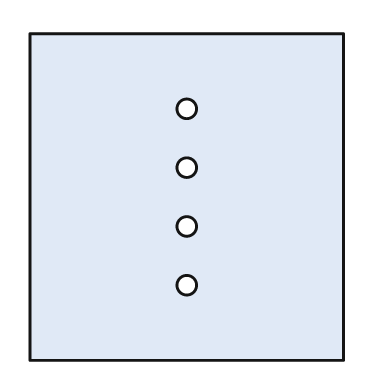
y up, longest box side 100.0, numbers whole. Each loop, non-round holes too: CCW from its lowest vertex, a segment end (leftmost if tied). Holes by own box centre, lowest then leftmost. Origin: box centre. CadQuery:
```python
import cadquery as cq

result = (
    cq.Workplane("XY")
    .moveTo(-48.0, -50.0)
    .lineTo(48.0, -50.0)
    .lineTo(48.0, 50.0)
    .lineTo(-48.0, 50.0)
    .close()
    .moveTo(0.0, -27.0)
    .circle(3.0)
    .moveTo(0.0, -9.0)
    .circle(3.0)
    .moveTo(0.0, 9.0)
    .circle(3.0)
    .moveTo(0.0, 27.0)
    .circle(3.0)
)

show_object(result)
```